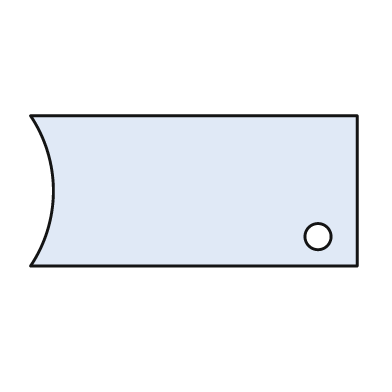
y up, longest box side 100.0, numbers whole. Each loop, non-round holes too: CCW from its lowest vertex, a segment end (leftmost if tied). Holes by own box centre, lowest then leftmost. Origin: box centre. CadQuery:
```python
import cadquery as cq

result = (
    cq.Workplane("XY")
    .moveTo(-50.0, -23.0)
    .lineTo(50.0, -23.0)
    .lineTo(50.0, 23.0)
    .lineTo(-50.0, 23.0)
    .threePointArc((-43.0, 0.0), (-50.0, -23.0))
    .close()
    .moveTo(38.0, -14.0)
    .circle(4.0)
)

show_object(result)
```